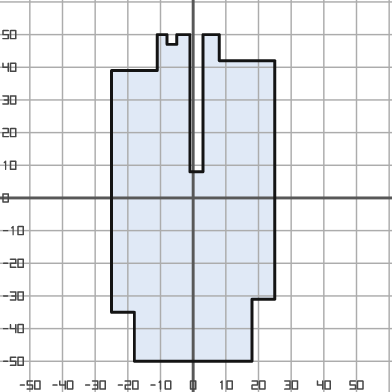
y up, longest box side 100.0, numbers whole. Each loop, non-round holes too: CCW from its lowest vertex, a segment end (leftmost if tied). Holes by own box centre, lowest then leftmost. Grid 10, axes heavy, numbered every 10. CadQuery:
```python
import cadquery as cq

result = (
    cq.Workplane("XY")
    .moveTo(-18.0, -50.0)
    .lineTo(18.0, -50.0)
    .lineTo(18.0, -31.0)
    .lineTo(25.0, -31.0)
    .lineTo(25.0, 42.0)
    .lineTo(8.0, 42.0)
    .lineTo(8.0, 50.0)
    .lineTo(3.0, 50.0)
    .lineTo(3.0, 8.0)
    .lineTo(-1.0, 8.0)
    .lineTo(-1.0, 50.0)
    .lineTo(-5.0, 50.0)
    .lineTo(-5.0, 47.0)
    .lineTo(-8.0, 47.0)
    .lineTo(-8.0, 50.0)
    .lineTo(-11.0, 50.0)
    .lineTo(-11.0, 39.0)
    .lineTo(-25.0, 39.0)
    .lineTo(-25.0, -35.0)
    .lineTo(-18.0, -35.0)
    .close()
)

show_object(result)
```